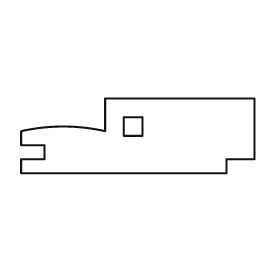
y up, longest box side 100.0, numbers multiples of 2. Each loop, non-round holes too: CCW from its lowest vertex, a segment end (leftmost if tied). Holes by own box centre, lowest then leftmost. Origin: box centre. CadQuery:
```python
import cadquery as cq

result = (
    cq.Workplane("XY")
    .moveTo(-50.0, -16.0)
    .lineTo(38.0, -16.0)
    .lineTo(38.0, -10.0)
    .lineTo(50.0, -10.0)
    .lineTo(50.0, 16.0)
    .lineTo(-14.0, 16.0)
    .lineTo(-14.0, 2.0)
    .threePointArc((-32.0, 4.0), (-50.0, 2.0))
    .lineTo(-50.0, -4.0)
    .lineTo(-40.0, -4.0)
    .lineTo(-40.0, -10.0)
    .lineTo(-50.0, -10.0)
    .close()
    .moveTo(-6.0, 0.0)
    .lineTo(2.0, 0.0)
    .lineTo(2.0, 8.0)
    .lineTo(-6.0, 8.0)
    .close()
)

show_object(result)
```